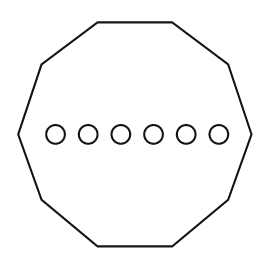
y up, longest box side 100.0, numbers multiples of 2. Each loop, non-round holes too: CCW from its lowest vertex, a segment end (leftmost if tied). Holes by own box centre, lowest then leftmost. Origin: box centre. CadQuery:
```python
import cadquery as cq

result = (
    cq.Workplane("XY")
    .moveTo(-16.0, -48.0)
    .lineTo(16.0, -48.0)
    .lineTo(40.0, -28.0)
    .lineTo(50.0, 0.0)
    .lineTo(40.0, 30.0)
    .lineTo(16.0, 48.0)
    .lineTo(-16.0, 48.0)
    .lineTo(-40.0, 30.0)
    .lineTo(-50.0, 0.0)
    .lineTo(-40.0, -28.0)
    .close()
    .moveTo(-34.0, 0.0)
    .circle(4.0)
    .moveTo(-20.0, 0.0)
    .circle(4.0)
    .moveTo(-6.0, 0.0)
    .circle(4.0)
    .moveTo(8.0, 0.0)
    .circle(4.0)
    .moveTo(22.0, 0.0)
    .circle(4.0)
    .moveTo(36.0, 0.0)
    .circle(4.0)
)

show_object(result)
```